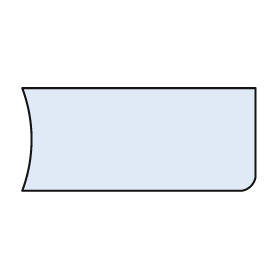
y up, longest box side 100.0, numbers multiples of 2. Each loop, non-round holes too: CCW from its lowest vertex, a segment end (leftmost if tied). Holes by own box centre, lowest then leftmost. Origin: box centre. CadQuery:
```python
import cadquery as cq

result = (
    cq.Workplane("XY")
    .moveTo(-50.0, -22.0)
    .lineTo(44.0, -22.0)
    .threePointArc((48.0, -20.0), (50.0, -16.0))
    .lineTo(50.0, 22.0)
    .lineTo(-50.0, 22.0)
    .threePointArc((-46.0, 0.0), (-50.0, -22.0))
    .close()
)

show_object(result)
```